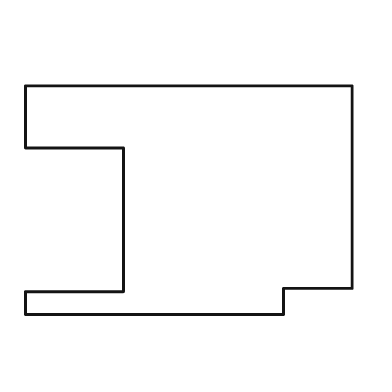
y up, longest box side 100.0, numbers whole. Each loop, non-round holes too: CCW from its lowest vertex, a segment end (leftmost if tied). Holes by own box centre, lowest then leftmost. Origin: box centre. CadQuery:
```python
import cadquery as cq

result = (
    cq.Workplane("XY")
    .moveTo(-50.0, -35.0)
    .lineTo(29.0, -35.0)
    .lineTo(29.0, -27.0)
    .lineTo(50.0, -27.0)
    .lineTo(50.0, 35.0)
    .lineTo(-50.0, 35.0)
    .lineTo(-50.0, 16.0)
    .lineTo(-20.0, 16.0)
    .lineTo(-20.0, -28.0)
    .lineTo(-50.0, -28.0)
    .close()
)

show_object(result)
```